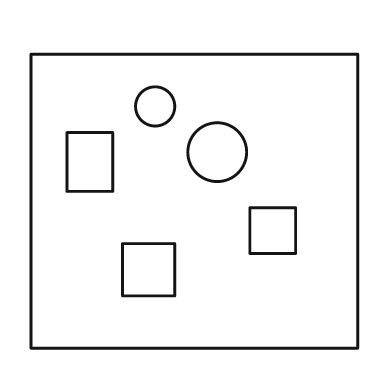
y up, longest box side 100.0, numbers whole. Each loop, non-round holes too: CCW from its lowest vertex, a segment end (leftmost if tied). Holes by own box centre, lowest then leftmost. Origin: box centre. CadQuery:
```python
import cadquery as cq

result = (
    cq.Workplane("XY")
    .moveTo(-50.0, -45.0)
    .lineTo(50.0, -45.0)
    .lineTo(50.0, 45.0)
    .lineTo(-50.0, 45.0)
    .close()
    .moveTo(-22.0, -29.0)
    .lineTo(-6.0, -29.0)
    .lineTo(-6.0, -13.0)
    .lineTo(-22.0, -13.0)
    .close()
    .moveTo(17.0, -16.0)
    .lineTo(31.0, -16.0)
    .lineTo(31.0, -2.0)
    .lineTo(17.0, -2.0)
    .close()
    .moveTo(-39.0, 3.0)
    .lineTo(-25.0, 3.0)
    .lineTo(-25.0, 21.0)
    .lineTo(-39.0, 21.0)
    .close()
    .moveTo(7.0, 15.0)
    .circle(9.0)
    .moveTo(-12.0, 29.0)
    .circle(6.0)
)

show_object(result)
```